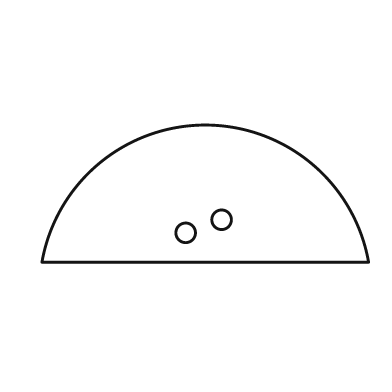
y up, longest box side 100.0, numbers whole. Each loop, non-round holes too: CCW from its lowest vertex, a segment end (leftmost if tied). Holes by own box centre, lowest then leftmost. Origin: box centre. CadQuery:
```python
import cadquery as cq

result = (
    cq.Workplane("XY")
    .moveTo(-50.0, -21.0)
    .lineTo(50.0, -21.0)
    .threePointArc((0.0, 21.0), (-50.0, -21.0))
    .close()
    .moveTo(-6.0, -12.0)
    .circle(3.0)
    .moveTo(5.0, -8.0)
    .circle(3.0)
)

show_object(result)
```